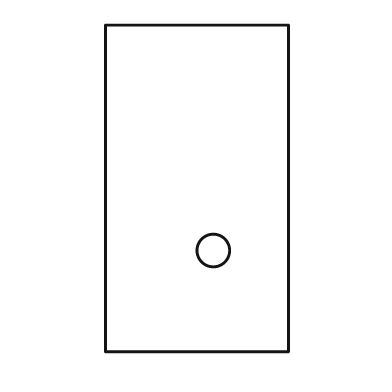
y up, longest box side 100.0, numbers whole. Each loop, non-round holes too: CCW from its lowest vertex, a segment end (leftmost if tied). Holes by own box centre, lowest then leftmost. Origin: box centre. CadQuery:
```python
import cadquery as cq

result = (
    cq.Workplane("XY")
    .moveTo(-28.0, -50.0)
    .lineTo(28.0, -50.0)
    .lineTo(28.0, 50.0)
    .lineTo(-28.0, 50.0)
    .close()
    .moveTo(5.0, -19.0)
    .circle(5.0)
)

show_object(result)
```